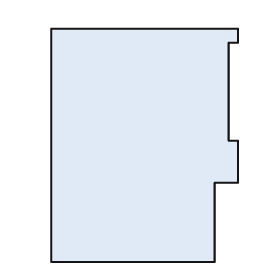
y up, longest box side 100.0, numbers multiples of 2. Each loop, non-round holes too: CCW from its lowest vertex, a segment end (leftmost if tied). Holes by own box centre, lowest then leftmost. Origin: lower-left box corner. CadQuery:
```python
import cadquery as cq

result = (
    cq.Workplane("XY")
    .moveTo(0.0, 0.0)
    .lineTo(70.0, 0.0)
    .lineTo(70.0, 34.0)
    .lineTo(80.0, 34.0)
    .lineTo(80.0, 52.0)
    .lineTo(76.0, 52.0)
    .lineTo(76.0, 94.0)
    .lineTo(80.0, 94.0)
    .lineTo(80.0, 100.0)
    .lineTo(0.0, 100.0)
    .close()
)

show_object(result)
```